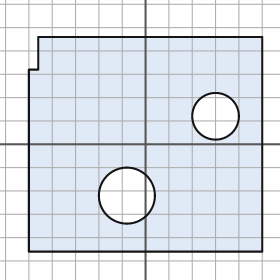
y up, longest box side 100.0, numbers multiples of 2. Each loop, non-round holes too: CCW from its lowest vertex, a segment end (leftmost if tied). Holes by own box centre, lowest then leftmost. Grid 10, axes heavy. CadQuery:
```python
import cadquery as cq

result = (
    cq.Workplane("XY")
    .moveTo(-50.0, -46.0)
    .lineTo(50.0, -46.0)
    .lineTo(50.0, 46.0)
    .lineTo(-46.0, 46.0)
    .lineTo(-46.0, 32.0)
    .lineTo(-50.0, 32.0)
    .close()
    .moveTo(-8.0, -22.0)
    .circle(12.0)
    .moveTo(30.0, 12.0)
    .circle(10.0)
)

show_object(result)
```